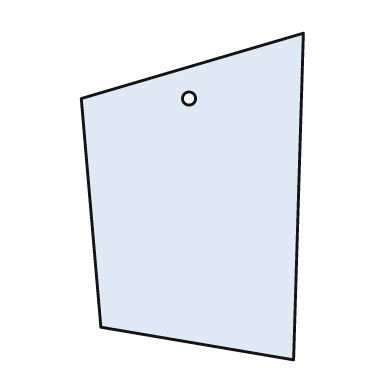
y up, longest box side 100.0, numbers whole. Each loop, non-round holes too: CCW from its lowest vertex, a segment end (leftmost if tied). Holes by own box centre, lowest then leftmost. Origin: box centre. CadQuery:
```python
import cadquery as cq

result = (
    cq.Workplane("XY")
    .moveTo(31.0, -50.0)
    .lineTo(34.0, 50.0)
    .lineTo(-34.0, 30.0)
    .lineTo(-28.0, -40.0)
    .close()
    .moveTo(-1.0, 30.0)
    .circle(2.0)
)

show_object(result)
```